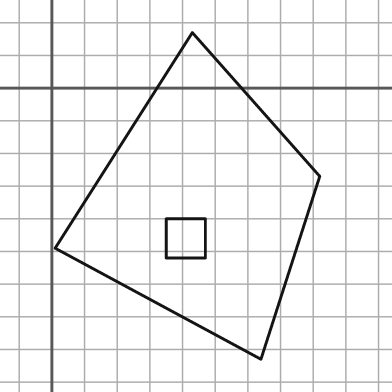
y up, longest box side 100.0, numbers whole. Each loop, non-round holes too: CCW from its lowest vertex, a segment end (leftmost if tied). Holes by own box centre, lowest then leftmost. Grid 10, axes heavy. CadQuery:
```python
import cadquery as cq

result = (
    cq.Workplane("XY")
    .moveTo(64.0, -83.0)
    .lineTo(82.0, -27.0)
    .lineTo(43.0, 17.0)
    .lineTo(1.0, -49.0)
    .close()
    .moveTo(35.0, -52.0)
    .lineTo(47.0, -52.0)
    .lineTo(47.0, -40.0)
    .lineTo(35.0, -40.0)
    .close()
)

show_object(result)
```